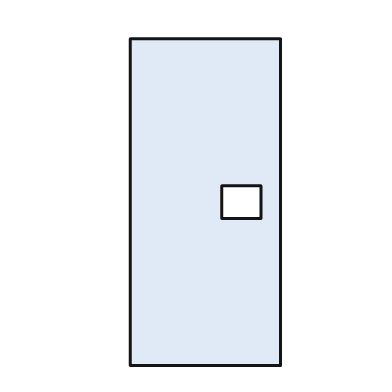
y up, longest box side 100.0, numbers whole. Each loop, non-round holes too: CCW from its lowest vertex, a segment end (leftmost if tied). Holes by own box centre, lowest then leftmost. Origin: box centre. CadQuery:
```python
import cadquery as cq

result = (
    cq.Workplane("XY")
    .moveTo(-23.0, -50.0)
    .lineTo(23.0, -50.0)
    .lineTo(23.0, 50.0)
    .lineTo(-23.0, 50.0)
    .close()
    .moveTo(5.0, -5.0)
    .lineTo(17.0, -5.0)
    .lineTo(17.0, 5.0)
    .lineTo(5.0, 5.0)
    .close()
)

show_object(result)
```